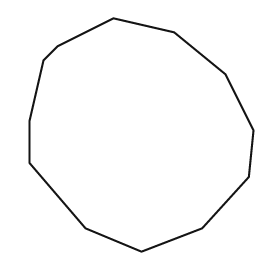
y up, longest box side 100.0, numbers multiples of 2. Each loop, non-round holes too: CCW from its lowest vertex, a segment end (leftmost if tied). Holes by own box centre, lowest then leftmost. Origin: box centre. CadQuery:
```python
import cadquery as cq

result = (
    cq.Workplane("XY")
    .moveTo(0.0, -50.0)
    .lineTo(26.0, -40.0)
    .lineTo(46.0, -18.0)
    .lineTo(48.0, 2.0)
    .lineTo(36.0, 26.0)
    .lineTo(14.0, 44.0)
    .lineTo(-12.0, 50.0)
    .lineTo(-36.0, 38.0)
    .lineTo(-42.0, 32.0)
    .lineTo(-48.0, 6.0)
    .lineTo(-48.0, -12.0)
    .lineTo(-24.0, -40.0)
    .close()
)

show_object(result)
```